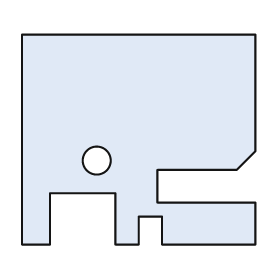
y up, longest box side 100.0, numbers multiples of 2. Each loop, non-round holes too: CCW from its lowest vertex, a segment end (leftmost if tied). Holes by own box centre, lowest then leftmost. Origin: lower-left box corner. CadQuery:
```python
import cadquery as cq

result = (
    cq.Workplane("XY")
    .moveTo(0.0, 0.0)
    .lineTo(12.0, 0.0)
    .lineTo(12.0, 22.0)
    .lineTo(40.0, 22.0)
    .lineTo(40.0, 0.0)
    .lineTo(50.0, 0.0)
    .lineTo(50.0, 12.0)
    .lineTo(60.0, 12.0)
    .lineTo(60.0, 0.0)
    .lineTo(100.0, 0.0)
    .lineTo(100.0, 18.0)
    .lineTo(58.0, 18.0)
    .lineTo(58.0, 32.0)
    .lineTo(92.0, 32.0)
    .lineTo(100.0, 40.0)
    .lineTo(100.0, 90.0)
    .lineTo(0.0, 90.0)
    .close()
    .moveTo(32.0, 36.0)
    .circle(6.0)
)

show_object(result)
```